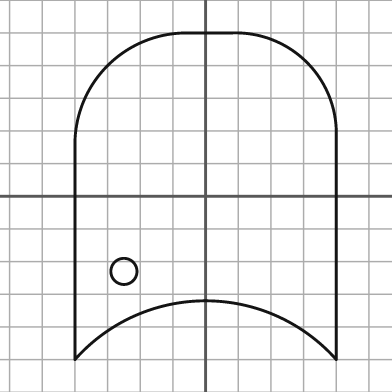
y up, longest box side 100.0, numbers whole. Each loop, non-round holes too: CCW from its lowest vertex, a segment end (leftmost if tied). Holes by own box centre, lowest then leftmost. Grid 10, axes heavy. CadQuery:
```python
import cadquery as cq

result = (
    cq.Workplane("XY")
    .moveTo(-40.0, -50.0)
    .threePointArc((0.0, -32.0), (40.0, -50.0))
    .lineTo(40.0, 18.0)
    .threePointArc((31.0, 41.0), (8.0, 50.0))
    .lineTo(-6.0, 50.0)
    .threePointArc((-30.0, 40.0), (-40.0, 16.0))
    .close()
    .moveTo(-25.0, -23.0)
    .circle(4.0)
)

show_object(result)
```